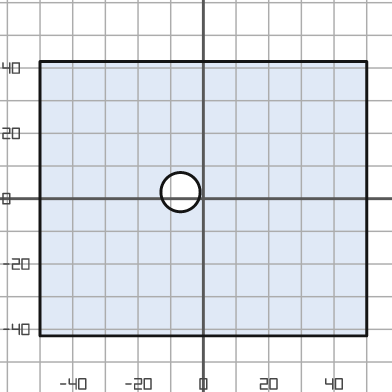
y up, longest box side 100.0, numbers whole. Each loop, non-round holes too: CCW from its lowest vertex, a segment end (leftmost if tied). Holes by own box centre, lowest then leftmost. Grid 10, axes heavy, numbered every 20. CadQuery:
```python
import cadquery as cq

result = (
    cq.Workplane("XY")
    .moveTo(-50.0, -42.0)
    .lineTo(50.0, -42.0)
    .lineTo(50.0, 42.0)
    .lineTo(-50.0, 42.0)
    .close()
    .moveTo(-7.0, 2.0)
    .circle(6.0)
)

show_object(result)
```